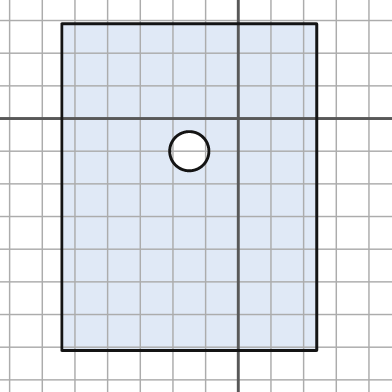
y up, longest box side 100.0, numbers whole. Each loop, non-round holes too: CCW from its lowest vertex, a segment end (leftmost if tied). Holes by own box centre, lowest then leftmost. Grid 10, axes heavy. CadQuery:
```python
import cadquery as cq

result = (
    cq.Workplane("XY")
    .moveTo(-54.0, -71.0)
    .lineTo(24.0, -71.0)
    .lineTo(24.0, 29.0)
    .lineTo(-54.0, 29.0)
    .close()
    .moveTo(-15.0, -10.0)
    .circle(6.0)
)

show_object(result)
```